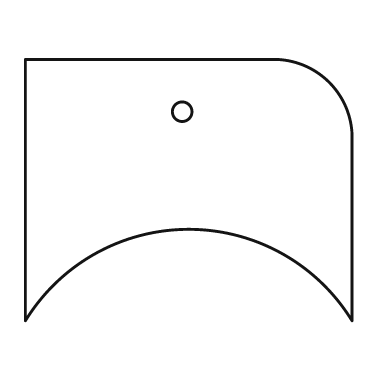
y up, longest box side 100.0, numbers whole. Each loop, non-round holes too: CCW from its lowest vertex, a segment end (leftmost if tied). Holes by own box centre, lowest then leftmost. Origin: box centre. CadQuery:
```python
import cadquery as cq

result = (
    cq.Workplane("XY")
    .moveTo(-50.0, -40.0)
    .threePointArc((0.0, -12.0), (50.0, -40.0))
    .lineTo(50.0, 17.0)
    .threePointArc((43.0, 33.0), (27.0, 40.0))
    .lineTo(-50.0, 40.0)
    .close()
    .moveTo(-2.0, 24.0)
    .circle(3.0)
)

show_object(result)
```